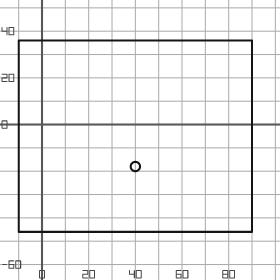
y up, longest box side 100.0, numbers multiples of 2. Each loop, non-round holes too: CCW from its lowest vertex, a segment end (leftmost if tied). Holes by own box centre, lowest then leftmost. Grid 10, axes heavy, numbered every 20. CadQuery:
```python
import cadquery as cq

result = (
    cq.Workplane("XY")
    .moveTo(-10.0, -46.0)
    .lineTo(90.0, -46.0)
    .lineTo(90.0, 36.0)
    .lineTo(-10.0, 36.0)
    .close()
    .moveTo(40.0, -18.0)
    .circle(2.0)
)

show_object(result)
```